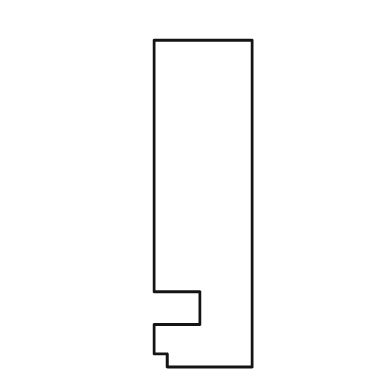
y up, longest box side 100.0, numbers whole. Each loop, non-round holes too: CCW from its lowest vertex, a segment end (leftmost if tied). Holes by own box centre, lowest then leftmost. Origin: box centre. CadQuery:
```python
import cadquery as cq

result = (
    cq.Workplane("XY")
    .moveTo(-11.0, -50.0)
    .lineTo(15.0, -50.0)
    .lineTo(15.0, 50.0)
    .lineTo(-15.0, 50.0)
    .lineTo(-15.0, -27.0)
    .lineTo(-1.0, -27.0)
    .lineTo(-1.0, -37.0)
    .lineTo(-15.0, -37.0)
    .lineTo(-15.0, -46.0)
    .lineTo(-11.0, -46.0)
    .close()
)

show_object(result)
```